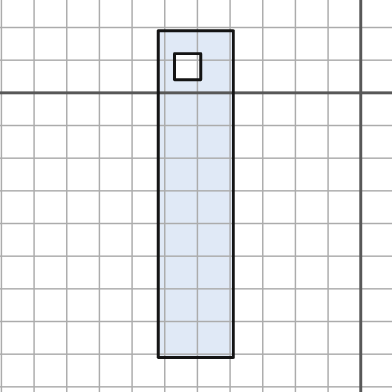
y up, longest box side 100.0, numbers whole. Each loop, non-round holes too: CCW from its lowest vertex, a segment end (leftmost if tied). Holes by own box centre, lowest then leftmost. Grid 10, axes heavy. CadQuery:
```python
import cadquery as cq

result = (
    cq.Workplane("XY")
    .moveTo(-62.0, -81.0)
    .lineTo(-39.0, -81.0)
    .lineTo(-39.0, 19.0)
    .lineTo(-62.0, 19.0)
    .close()
    .moveTo(-57.0, 4.0)
    .lineTo(-49.0, 4.0)
    .lineTo(-49.0, 12.0)
    .lineTo(-57.0, 12.0)
    .close()
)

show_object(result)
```